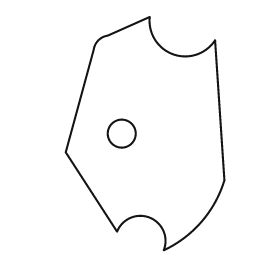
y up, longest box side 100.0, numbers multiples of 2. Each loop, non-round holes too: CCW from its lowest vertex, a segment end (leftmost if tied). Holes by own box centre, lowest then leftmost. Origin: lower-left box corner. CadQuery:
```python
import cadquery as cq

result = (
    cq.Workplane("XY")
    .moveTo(42.0, 0.0)
    .threePointArc((58.0, 12.0), (68.0, 30.0))
    .lineTo(64.0, 90.0)
    .threePointArc((46.0, 84.0), (36.0, 100.0))
    .lineTo(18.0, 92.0)
    .threePointArc((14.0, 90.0), (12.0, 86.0))
    .lineTo(0.0, 42.0)
    .lineTo(22.0, 8.0)
    .threePointArc((36.0, 14.0), (42.0, 0.0))
    .close()
    .moveTo(24.0, 50.0)
    .circle(6.0)
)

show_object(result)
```